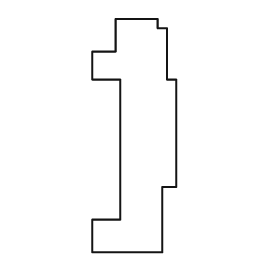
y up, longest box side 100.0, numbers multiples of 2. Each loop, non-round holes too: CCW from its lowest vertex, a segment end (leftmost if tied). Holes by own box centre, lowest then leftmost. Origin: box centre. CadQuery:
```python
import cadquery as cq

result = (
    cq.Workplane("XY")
    .moveTo(-18.0, -50.0)
    .lineTo(12.0, -50.0)
    .lineTo(12.0, -22.0)
    .lineTo(18.0, -22.0)
    .lineTo(18.0, 24.0)
    .lineTo(14.0, 24.0)
    .lineTo(14.0, 46.0)
    .lineTo(10.0, 46.0)
    .lineTo(10.0, 50.0)
    .lineTo(-8.0, 50.0)
    .lineTo(-8.0, 36.0)
    .lineTo(-18.0, 36.0)
    .lineTo(-18.0, 24.0)
    .lineTo(-6.0, 24.0)
    .lineTo(-6.0, -36.0)
    .lineTo(-18.0, -36.0)
    .close()
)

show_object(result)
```